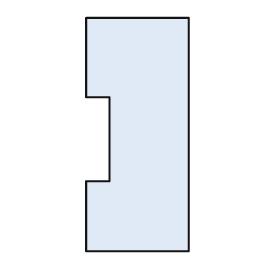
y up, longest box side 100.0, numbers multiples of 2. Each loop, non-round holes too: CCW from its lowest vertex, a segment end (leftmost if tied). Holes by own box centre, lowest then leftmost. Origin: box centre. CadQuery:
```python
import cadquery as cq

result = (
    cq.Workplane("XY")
    .moveTo(-22.0, -50.0)
    .lineTo(22.0, -50.0)
    .lineTo(22.0, 50.0)
    .lineTo(-22.0, 50.0)
    .lineTo(-22.0, 16.0)
    .lineTo(-12.0, 16.0)
    .lineTo(-12.0, -20.0)
    .lineTo(-22.0, -20.0)
    .close()
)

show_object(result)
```